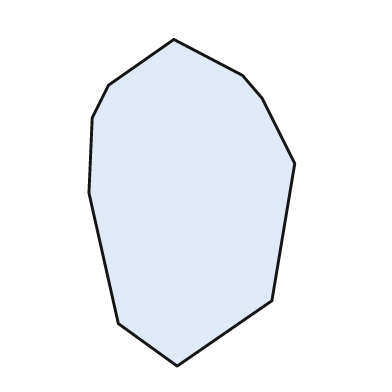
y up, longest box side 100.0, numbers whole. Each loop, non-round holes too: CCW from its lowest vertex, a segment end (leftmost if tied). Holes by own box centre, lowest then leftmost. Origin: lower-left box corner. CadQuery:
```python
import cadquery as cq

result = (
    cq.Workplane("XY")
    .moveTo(27.0, 0.0)
    .lineTo(56.0, 20.0)
    .lineTo(63.0, 62.0)
    .lineTo(53.0, 82.0)
    .lineTo(47.0, 89.0)
    .lineTo(26.0, 100.0)
    .lineTo(6.0, 86.0)
    .lineTo(1.0, 76.0)
    .lineTo(0.0, 53.0)
    .lineTo(9.0, 13.0)
    .close()
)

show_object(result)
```